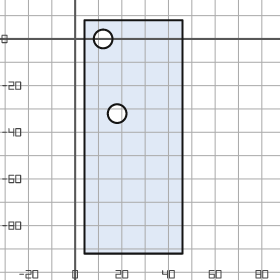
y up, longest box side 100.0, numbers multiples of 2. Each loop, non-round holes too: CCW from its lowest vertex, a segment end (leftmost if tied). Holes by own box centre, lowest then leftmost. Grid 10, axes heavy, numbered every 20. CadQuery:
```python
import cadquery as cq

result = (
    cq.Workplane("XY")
    .moveTo(4.0, -92.0)
    .lineTo(46.0, -92.0)
    .lineTo(46.0, 8.0)
    .lineTo(4.0, 8.0)
    .close()
    .moveTo(18.0, -32.0)
    .circle(4.0)
    .moveTo(12.0, 0.0)
    .circle(4.0)
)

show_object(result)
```